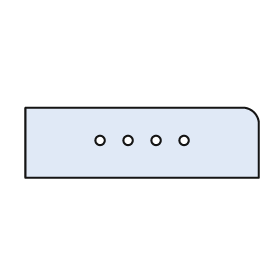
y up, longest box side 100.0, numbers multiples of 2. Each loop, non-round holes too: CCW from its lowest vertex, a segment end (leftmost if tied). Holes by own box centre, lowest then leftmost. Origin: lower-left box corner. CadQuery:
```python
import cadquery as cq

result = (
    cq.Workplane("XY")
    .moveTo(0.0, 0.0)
    .lineTo(100.0, 0.0)
    .lineTo(100.0, 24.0)
    .threePointArc((98.0, 28.0), (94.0, 30.0))
    .lineTo(0.0, 30.0)
    .close()
    .moveTo(32.0, 16.0)
    .circle(2.0)
    .moveTo(44.0, 16.0)
    .circle(2.0)
    .moveTo(56.0, 16.0)
    .circle(2.0)
    .moveTo(68.0, 16.0)
    .circle(2.0)
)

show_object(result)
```